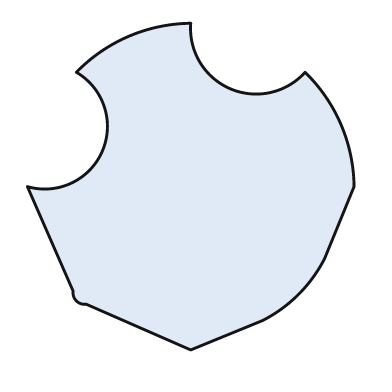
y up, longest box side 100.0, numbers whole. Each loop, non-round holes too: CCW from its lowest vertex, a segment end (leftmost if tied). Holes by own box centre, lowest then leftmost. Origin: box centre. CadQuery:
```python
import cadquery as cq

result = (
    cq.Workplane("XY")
    .moveTo(0.0, -50.0)
    .lineTo(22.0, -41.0)
    .threePointArc((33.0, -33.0), (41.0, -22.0))
    .lineTo(50.0, 0.0)
    .threePointArc((46.0, 19.0), (35.0, 35.0))
    .threePointArc((12.0, 30.0), (0.0, 50.0))
    .threePointArc((-19.0, 46.0), (-35.0, 35.0))
    .threePointArc((-27.0, 11.0), (-50.0, 0.0))
    .lineTo(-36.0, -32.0)
    .threePointArc((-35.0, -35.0), (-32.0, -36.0))
    .close()
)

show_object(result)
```